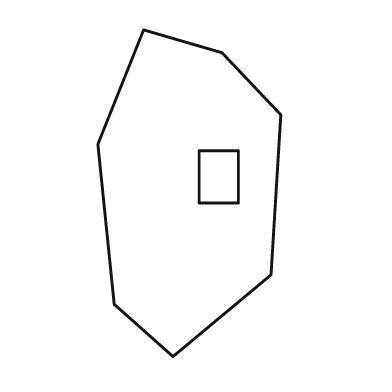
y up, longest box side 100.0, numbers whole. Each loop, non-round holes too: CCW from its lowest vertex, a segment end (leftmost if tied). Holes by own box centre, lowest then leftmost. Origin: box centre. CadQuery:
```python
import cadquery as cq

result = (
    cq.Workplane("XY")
    .moveTo(-5.0, -50.0)
    .lineTo(25.0, -25.0)
    .lineTo(28.0, 24.0)
    .lineTo(10.0, 43.0)
    .lineTo(-14.0, 50.0)
    .lineTo(-28.0, 15.0)
    .lineTo(-23.0, -34.0)
    .close()
    .moveTo(3.0, -3.0)
    .lineTo(15.0, -3.0)
    .lineTo(15.0, 13.0)
    .lineTo(3.0, 13.0)
    .close()
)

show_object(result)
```